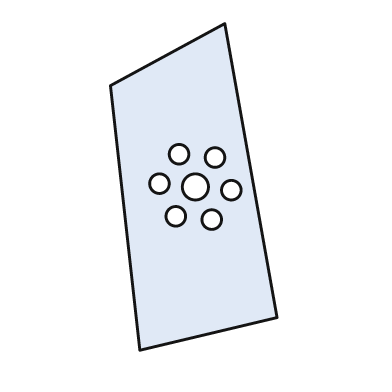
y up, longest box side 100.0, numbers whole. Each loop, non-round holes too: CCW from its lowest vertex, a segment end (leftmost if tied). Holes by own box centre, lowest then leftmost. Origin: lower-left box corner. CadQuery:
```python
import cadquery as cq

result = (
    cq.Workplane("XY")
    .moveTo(9.0, 0.0)
    .lineTo(51.0, 10.0)
    .lineTo(35.0, 100.0)
    .lineTo(0.0, 81.0)
    .close()
    .moveTo(31.0, 40.0)
    .circle(3.0)
    .moveTo(20.0, 41.0)
    .circle(3.0)
    .moveTo(37.0, 49.0)
    .circle(3.0)
    .moveTo(26.0, 50.0)
    .circle(4.0)
    .moveTo(15.0, 51.0)
    .circle(3.0)
    .moveTo(32.0, 59.0)
    .circle(3.0)
    .moveTo(21.0, 60.0)
    .circle(3.0)
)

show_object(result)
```